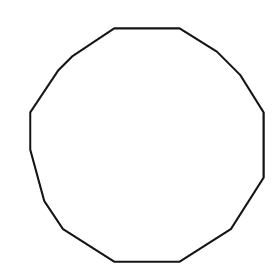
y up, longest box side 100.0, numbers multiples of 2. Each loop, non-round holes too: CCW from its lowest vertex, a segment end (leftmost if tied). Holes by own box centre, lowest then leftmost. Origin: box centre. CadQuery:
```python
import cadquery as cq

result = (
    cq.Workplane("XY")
    .moveTo(-14.0, -50.0)
    .lineTo(14.0, -50.0)
    .lineTo(36.0, -36.0)
    .lineTo(50.0, -14.0)
    .lineTo(50.0, 14.0)
    .lineTo(40.0, 30.0)
    .lineTo(30.0, 40.0)
    .lineTo(14.0, 50.0)
    .lineTo(-14.0, 50.0)
    .lineTo(-32.0, 38.0)
    .lineTo(-38.0, 32.0)
    .lineTo(-50.0, 14.0)
    .lineTo(-50.0, -2.0)
    .lineTo(-44.0, -24.0)
    .lineTo(-36.0, -36.0)
    .close()
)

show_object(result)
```